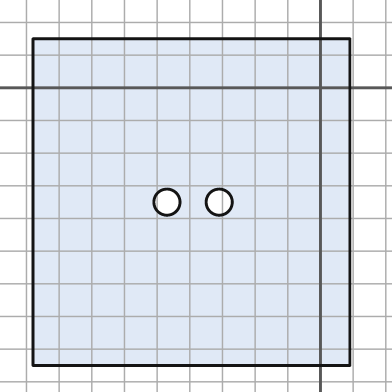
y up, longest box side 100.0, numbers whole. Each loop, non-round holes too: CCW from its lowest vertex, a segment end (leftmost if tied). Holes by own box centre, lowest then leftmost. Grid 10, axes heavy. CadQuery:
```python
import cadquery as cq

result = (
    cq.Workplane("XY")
    .moveTo(-88.0, -85.0)
    .lineTo(9.0, -85.0)
    .lineTo(9.0, 15.0)
    .lineTo(-88.0, 15.0)
    .close()
    .moveTo(-47.0, -35.0)
    .circle(4.0)
    .moveTo(-31.0, -35.0)
    .circle(4.0)
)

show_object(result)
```